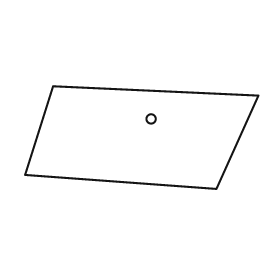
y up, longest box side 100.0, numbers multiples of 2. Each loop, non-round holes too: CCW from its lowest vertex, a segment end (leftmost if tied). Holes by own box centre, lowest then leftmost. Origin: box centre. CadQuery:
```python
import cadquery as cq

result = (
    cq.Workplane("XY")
    .moveTo(32.0, -22.0)
    .lineTo(50.0, 18.0)
    .lineTo(-38.0, 22.0)
    .lineTo(-50.0, -16.0)
    .close()
    .moveTo(4.0, 8.0)
    .circle(2.0)
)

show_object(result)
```